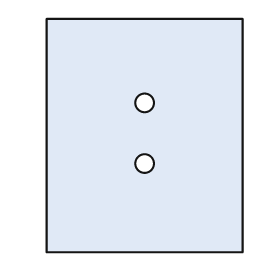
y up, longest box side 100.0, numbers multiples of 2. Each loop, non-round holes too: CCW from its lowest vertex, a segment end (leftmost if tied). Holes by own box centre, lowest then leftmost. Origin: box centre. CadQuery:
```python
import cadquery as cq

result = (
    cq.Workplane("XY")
    .moveTo(-42.0, -50.0)
    .lineTo(42.0, -50.0)
    .lineTo(42.0, 50.0)
    .lineTo(-42.0, 50.0)
    .close()
    .moveTo(0.0, -12.0)
    .circle(4.0)
    .moveTo(0.0, 14.0)
    .circle(4.0)
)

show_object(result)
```